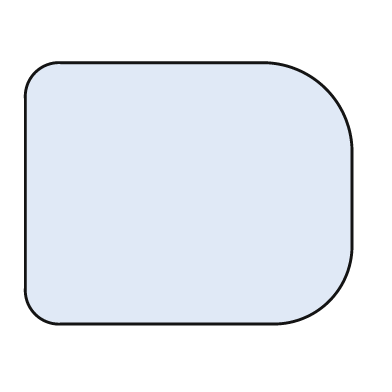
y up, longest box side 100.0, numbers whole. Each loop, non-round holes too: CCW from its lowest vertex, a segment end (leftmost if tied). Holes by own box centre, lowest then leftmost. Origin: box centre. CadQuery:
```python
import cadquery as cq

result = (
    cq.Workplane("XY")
    .moveTo(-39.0, -40.0)
    .lineTo(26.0, -40.0)
    .threePointArc((43.0, -33.0), (50.0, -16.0))
    .lineTo(50.0, 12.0)
    .threePointArc((42.0, 32.0), (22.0, 40.0))
    .lineTo(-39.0, 40.0)
    .threePointArc((-47.0, 37.0), (-50.0, 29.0))
    .lineTo(-50.0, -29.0)
    .threePointArc((-47.0, -37.0), (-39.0, -40.0))
    .close()
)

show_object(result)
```